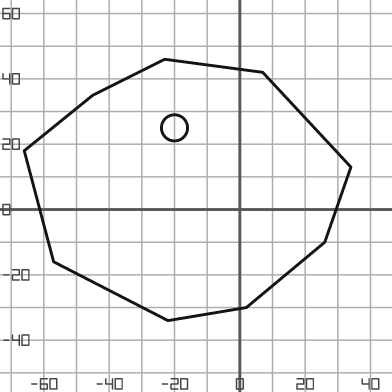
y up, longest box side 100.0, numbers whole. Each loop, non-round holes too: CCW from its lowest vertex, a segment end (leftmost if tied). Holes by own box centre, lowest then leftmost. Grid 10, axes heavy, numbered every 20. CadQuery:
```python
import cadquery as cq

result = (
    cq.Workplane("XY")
    .moveTo(-22.0, -34.0)
    .lineTo(2.0, -30.0)
    .lineTo(26.0, -10.0)
    .lineTo(34.0, 13.0)
    .lineTo(7.0, 42.0)
    .lineTo(-23.0, 46.0)
    .lineTo(-45.0, 35.0)
    .lineTo(-66.0, 18.0)
    .lineTo(-57.0, -16.0)
    .close()
    .moveTo(-20.0, 25.0)
    .circle(4.0)
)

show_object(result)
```